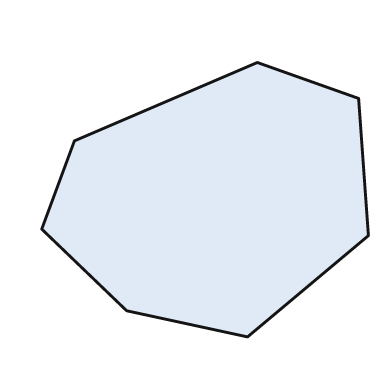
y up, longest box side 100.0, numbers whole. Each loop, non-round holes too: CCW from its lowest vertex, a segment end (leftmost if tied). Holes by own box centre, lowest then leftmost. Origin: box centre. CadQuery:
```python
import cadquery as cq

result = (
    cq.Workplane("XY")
    .moveTo(13.0, -42.0)
    .lineTo(50.0, -11.0)
    .lineTo(47.0, 31.0)
    .lineTo(16.0, 42.0)
    .lineTo(-40.0, 18.0)
    .lineTo(-50.0, -9.0)
    .lineTo(-24.0, -34.0)
    .close()
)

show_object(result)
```